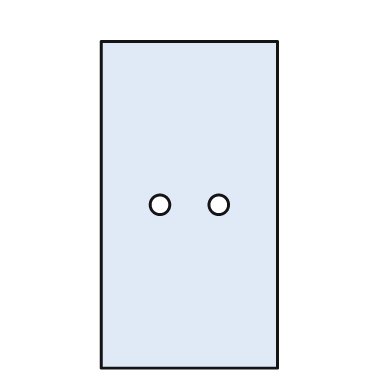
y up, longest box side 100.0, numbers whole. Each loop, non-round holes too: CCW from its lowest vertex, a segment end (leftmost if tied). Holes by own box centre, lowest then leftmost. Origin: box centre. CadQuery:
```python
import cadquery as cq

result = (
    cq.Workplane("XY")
    .moveTo(-27.0, -50.0)
    .lineTo(27.0, -50.0)
    .lineTo(27.0, 50.0)
    .lineTo(-27.0, 50.0)
    .close()
    .moveTo(-9.0, 0.0)
    .circle(3.0)
    .moveTo(9.0, 0.0)
    .circle(3.0)
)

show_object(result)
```